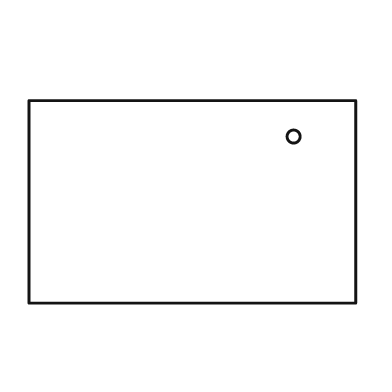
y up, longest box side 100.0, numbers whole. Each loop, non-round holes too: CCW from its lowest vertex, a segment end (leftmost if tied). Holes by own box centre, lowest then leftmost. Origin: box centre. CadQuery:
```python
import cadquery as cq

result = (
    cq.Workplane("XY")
    .moveTo(-50.0, -31.0)
    .lineTo(50.0, -31.0)
    .lineTo(50.0, 31.0)
    .lineTo(-50.0, 31.0)
    .close()
    .moveTo(31.0, 20.0)
    .circle(2.0)
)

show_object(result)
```